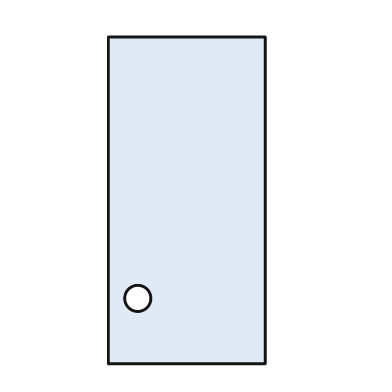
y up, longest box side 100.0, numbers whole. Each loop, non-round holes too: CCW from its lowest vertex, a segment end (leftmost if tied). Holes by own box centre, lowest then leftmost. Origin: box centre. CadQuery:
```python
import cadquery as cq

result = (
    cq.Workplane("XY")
    .moveTo(-24.0, -50.0)
    .lineTo(24.0, -50.0)
    .lineTo(24.0, 50.0)
    .lineTo(-24.0, 50.0)
    .close()
    .moveTo(-15.0, -30.0)
    .circle(4.0)
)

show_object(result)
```